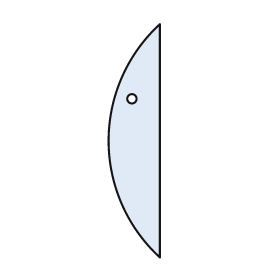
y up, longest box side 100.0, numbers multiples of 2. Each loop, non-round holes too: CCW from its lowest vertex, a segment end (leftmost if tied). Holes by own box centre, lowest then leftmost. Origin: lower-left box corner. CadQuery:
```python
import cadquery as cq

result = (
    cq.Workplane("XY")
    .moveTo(22.0, 0.0)
    .lineTo(22.0, 100.0)
    .threePointArc((0.0, 50.0), (22.0, 0.0))
    .close()
    .moveTo(10.0, 68.0)
    .circle(2.0)
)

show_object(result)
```